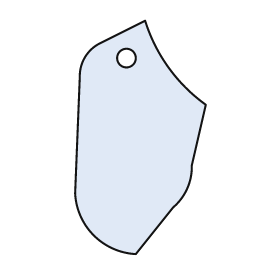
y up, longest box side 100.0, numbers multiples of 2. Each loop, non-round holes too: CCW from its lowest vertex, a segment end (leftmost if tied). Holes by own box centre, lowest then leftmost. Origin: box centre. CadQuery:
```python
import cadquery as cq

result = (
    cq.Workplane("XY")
    .moveTo(-2.0, -50.0)
    .lineTo(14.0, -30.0)
    .threePointArc((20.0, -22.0), (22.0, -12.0))
    .lineTo(28.0, 14.0)
    .threePointArc((12.0, 30.0), (2.0, 50.0))
    .lineTo(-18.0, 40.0)
    .threePointArc((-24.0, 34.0), (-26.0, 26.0))
    .lineTo(-28.0, -24.0)
    .threePointArc((-20.0, -42.0), (-2.0, -50.0))
    .close()
    .moveTo(-6.0, 34.0)
    .circle(4.0)
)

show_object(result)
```